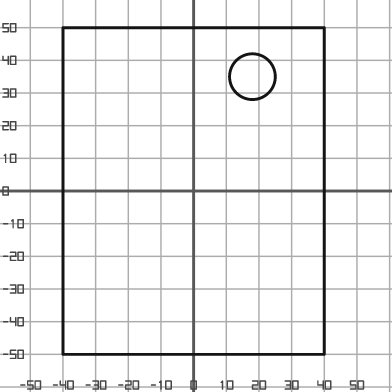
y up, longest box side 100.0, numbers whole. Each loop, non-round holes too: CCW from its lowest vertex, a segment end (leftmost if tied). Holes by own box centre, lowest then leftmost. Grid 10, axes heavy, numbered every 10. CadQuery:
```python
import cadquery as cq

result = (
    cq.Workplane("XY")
    .moveTo(-40.0, -50.0)
    .lineTo(40.0, -50.0)
    .lineTo(40.0, 50.0)
    .lineTo(-40.0, 50.0)
    .close()
    .moveTo(18.0, 35.0)
    .circle(7.0)
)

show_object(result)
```